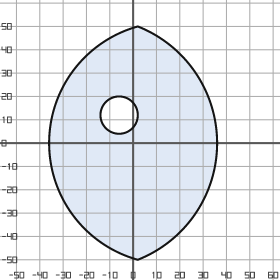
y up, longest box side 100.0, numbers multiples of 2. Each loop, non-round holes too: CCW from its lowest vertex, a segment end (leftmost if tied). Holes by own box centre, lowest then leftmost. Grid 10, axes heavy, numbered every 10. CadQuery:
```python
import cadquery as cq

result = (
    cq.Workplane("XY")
    .moveTo(2.0, -50.0)
    .threePointArc((36.0, 0.0), (2.0, 50.0))
    .threePointArc((-36.0, 0.0), (2.0, -50.0))
    .close()
    .moveTo(-6.0, 12.0)
    .circle(8.0)
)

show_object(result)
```